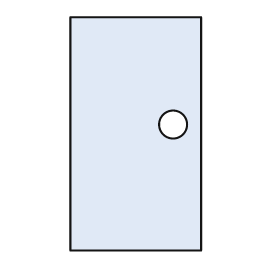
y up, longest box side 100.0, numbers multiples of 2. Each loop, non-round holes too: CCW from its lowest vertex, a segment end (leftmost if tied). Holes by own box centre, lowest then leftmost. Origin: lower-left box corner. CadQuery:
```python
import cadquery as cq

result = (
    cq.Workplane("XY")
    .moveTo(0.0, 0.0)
    .lineTo(56.0, 0.0)
    .lineTo(56.0, 100.0)
    .lineTo(0.0, 100.0)
    .close()
    .moveTo(44.0, 54.0)
    .circle(6.0)
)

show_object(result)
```